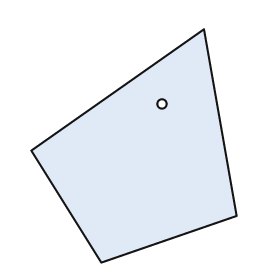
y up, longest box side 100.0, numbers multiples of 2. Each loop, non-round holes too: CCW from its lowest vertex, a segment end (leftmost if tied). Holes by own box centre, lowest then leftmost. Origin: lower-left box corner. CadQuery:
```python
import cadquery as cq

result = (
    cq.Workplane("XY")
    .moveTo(30.0, 0.0)
    .lineTo(88.0, 20.0)
    .lineTo(74.0, 100.0)
    .lineTo(0.0, 48.0)
    .close()
    .moveTo(56.0, 68.0)
    .circle(2.0)
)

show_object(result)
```